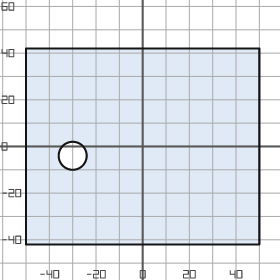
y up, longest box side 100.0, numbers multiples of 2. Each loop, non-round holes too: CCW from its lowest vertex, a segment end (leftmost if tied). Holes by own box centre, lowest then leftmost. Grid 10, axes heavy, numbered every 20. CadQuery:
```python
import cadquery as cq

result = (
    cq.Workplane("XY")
    .moveTo(-50.0, -42.0)
    .lineTo(50.0, -42.0)
    .lineTo(50.0, 42.0)
    .lineTo(-50.0, 42.0)
    .close()
    .moveTo(-30.0, -4.0)
    .circle(6.0)
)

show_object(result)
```